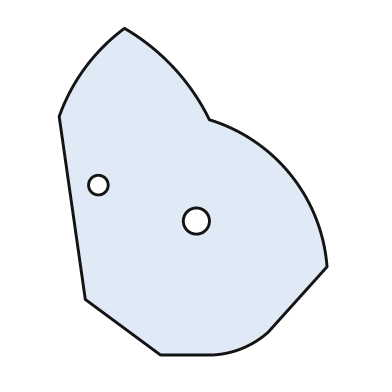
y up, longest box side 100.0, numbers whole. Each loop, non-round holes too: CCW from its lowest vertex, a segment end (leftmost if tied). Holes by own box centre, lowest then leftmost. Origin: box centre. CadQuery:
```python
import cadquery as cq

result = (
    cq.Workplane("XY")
    .moveTo(-10.0, -50.0)
    .lineTo(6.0, -50.0)
    .threePointArc((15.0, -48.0), (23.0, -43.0))
    .lineTo(41.0, -23.0)
    .threePointArc((30.0, 5.0), (5.0, 22.0))
    .threePointArc((-6.0, 38.0), (-21.0, 50.0))
    .threePointArc((-33.0, 38.0), (-41.0, 23.0))
    .lineTo(-33.0, -33.0)
    .close()
    .moveTo(1.0, -9.0)
    .circle(4.0)
    .moveTo(-29.0, 2.0)
    .circle(3.0)
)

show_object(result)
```